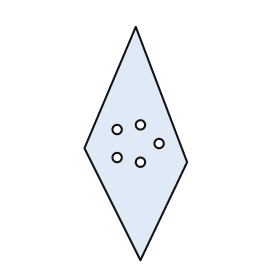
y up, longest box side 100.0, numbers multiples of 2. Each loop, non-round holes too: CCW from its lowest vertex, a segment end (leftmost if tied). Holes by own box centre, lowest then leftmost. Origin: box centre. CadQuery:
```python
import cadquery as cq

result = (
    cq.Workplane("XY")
    .moveTo(2.0, -50.0)
    .lineTo(22.0, -8.0)
    .lineTo(0.0, 50.0)
    .lineTo(-22.0, -2.0)
    .close()
    .moveTo(2.0, -8.0)
    .circle(2.0)
    .moveTo(-8.0, -6.0)
    .circle(2.0)
    .moveTo(10.0, 0.0)
    .circle(2.0)
    .moveTo(-8.0, 6.0)
    .circle(2.0)
    .moveTo(2.0, 8.0)
    .circle(2.0)
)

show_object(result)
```